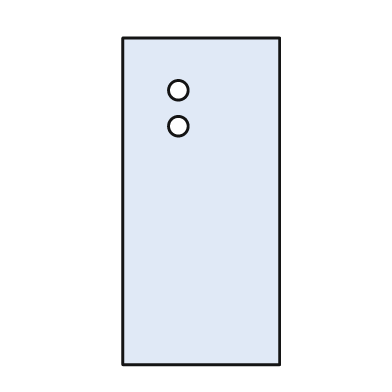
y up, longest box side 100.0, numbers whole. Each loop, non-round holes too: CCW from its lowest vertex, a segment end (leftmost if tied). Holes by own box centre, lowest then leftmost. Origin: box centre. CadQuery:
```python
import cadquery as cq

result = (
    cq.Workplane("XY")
    .moveTo(-24.0, -50.0)
    .lineTo(24.0, -50.0)
    .lineTo(24.0, 50.0)
    .lineTo(-24.0, 50.0)
    .close()
    .moveTo(-7.0, 23.0)
    .circle(3.0)
    .moveTo(-7.0, 34.0)
    .circle(3.0)
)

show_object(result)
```